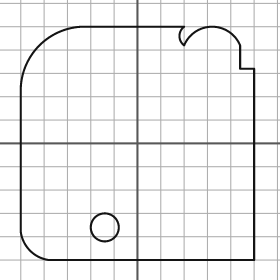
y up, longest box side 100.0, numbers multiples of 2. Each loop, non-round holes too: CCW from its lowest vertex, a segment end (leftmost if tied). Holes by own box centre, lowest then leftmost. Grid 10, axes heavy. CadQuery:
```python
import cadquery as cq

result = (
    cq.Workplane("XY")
    .moveTo(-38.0, -50.0)
    .lineTo(50.0, -50.0)
    .lineTo(50.0, 32.0)
    .lineTo(44.0, 32.0)
    .lineTo(44.0, 42.0)
    .threePointArc((32.0, 50.0), (20.0, 42.0))
    .threePointArc((18.0, 46.0), (20.0, 50.0))
    .lineTo(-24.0, 50.0)
    .threePointArc((-42.0, 42.0), (-50.0, 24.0))
    .lineTo(-50.0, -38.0)
    .threePointArc((-46.0, -46.0), (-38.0, -50.0))
    .close()
    .moveTo(-14.0, -36.0)
    .circle(6.0)
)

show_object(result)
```